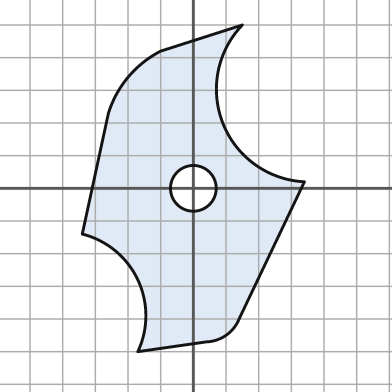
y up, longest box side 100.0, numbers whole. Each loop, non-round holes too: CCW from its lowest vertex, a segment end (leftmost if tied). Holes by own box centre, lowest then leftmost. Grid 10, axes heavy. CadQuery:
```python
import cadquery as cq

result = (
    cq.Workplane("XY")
    .moveTo(-17.0, -50.0)
    .lineTo(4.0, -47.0)
    .threePointArc((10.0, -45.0), (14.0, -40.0))
    .lineTo(34.0, 2.0)
    .threePointArc((9.0, 20.0), (15.0, 50.0))
    .lineTo(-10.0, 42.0)
    .threePointArc((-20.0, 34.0), (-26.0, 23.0))
    .lineTo(-34.0, -14.0)
    .threePointArc((-17.0, -28.0), (-17.0, -50.0))
    .close()
    .moveTo(0.0, 0.0)
    .circle(7.0)
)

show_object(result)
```